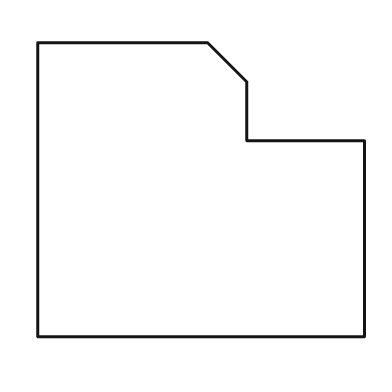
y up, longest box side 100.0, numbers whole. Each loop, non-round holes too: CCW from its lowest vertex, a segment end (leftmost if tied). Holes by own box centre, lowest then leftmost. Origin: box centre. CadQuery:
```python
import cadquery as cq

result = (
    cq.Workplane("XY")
    .moveTo(-50.0, -45.0)
    .lineTo(50.0, -45.0)
    .lineTo(50.0, 15.0)
    .lineTo(14.0, 15.0)
    .lineTo(14.0, 33.0)
    .lineTo(2.0, 45.0)
    .lineTo(-50.0, 45.0)
    .close()
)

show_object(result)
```